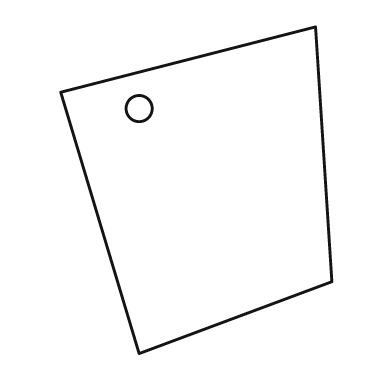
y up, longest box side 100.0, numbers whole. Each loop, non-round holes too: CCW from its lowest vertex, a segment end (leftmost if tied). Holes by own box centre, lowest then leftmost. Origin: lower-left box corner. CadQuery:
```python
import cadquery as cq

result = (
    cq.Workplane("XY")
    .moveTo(24.0, 0.0)
    .lineTo(83.0, 22.0)
    .lineTo(78.0, 100.0)
    .lineTo(0.0, 80.0)
    .close()
    .moveTo(24.0, 75.0)
    .circle(4.0)
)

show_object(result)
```